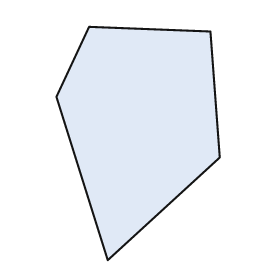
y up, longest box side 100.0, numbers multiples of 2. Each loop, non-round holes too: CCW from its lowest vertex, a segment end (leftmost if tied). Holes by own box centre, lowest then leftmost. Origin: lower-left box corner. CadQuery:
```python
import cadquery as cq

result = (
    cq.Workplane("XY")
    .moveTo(22.0, 0.0)
    .lineTo(70.0, 44.0)
    .lineTo(66.0, 98.0)
    .lineTo(14.0, 100.0)
    .lineTo(0.0, 70.0)
    .close()
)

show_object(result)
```